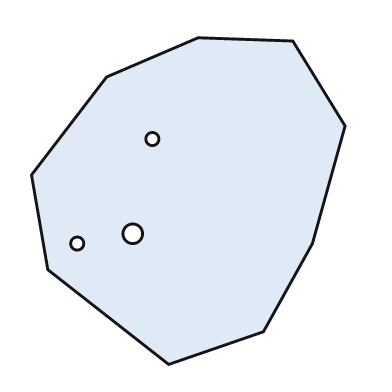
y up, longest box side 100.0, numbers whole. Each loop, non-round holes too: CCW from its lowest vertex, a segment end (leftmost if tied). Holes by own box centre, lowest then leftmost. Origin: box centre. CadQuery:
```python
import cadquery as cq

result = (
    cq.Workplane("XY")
    .moveTo(-6.0, -50.0)
    .lineTo(23.0, -40.0)
    .lineTo(38.0, -13.0)
    .lineTo(48.0, 23.0)
    .lineTo(32.0, 49.0)
    .lineTo(3.0, 50.0)
    .lineTo(-25.0, 38.0)
    .lineTo(-48.0, 8.0)
    .lineTo(-43.0, -21.0)
    .close()
    .moveTo(-34.0, -13.0)
    .circle(2.0)
    .moveTo(-17.0, -10.0)
    .circle(3.0)
    .moveTo(-11.0, 19.0)
    .circle(2.0)
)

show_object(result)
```